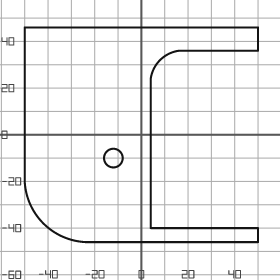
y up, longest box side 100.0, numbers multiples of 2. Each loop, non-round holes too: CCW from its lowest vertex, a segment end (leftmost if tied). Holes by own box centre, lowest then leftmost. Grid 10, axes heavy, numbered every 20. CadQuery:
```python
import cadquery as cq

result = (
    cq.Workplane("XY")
    .moveTo(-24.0, -46.0)
    .lineTo(50.0, -46.0)
    .lineTo(50.0, -40.0)
    .lineTo(4.0, -40.0)
    .lineTo(4.0, 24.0)
    .threePointArc((8.0, 32.0), (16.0, 36.0))
    .lineTo(50.0, 36.0)
    .lineTo(50.0, 46.0)
    .lineTo(-50.0, 46.0)
    .lineTo(-50.0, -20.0)
    .threePointArc((-42.0, -38.0), (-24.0, -46.0))
    .close()
    .moveTo(-12.0, -10.0)
    .circle(4.0)
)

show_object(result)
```